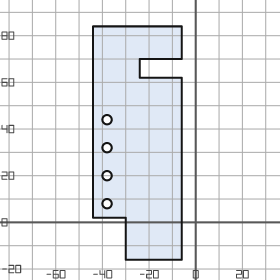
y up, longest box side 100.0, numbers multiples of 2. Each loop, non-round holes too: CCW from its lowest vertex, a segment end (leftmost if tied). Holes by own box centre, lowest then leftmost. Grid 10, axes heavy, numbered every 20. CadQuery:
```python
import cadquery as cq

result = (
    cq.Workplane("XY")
    .moveTo(-30.0, -16.0)
    .lineTo(-6.0, -16.0)
    .lineTo(-6.0, 62.0)
    .lineTo(-24.0, 62.0)
    .lineTo(-24.0, 70.0)
    .lineTo(-6.0, 70.0)
    .lineTo(-6.0, 84.0)
    .lineTo(-44.0, 84.0)
    .lineTo(-44.0, 2.0)
    .lineTo(-30.0, 2.0)
    .close()
    .moveTo(-38.0, 8.0)
    .circle(2.0)
    .moveTo(-38.0, 20.0)
    .circle(2.0)
    .moveTo(-38.0, 32.0)
    .circle(2.0)
    .moveTo(-38.0, 44.0)
    .circle(2.0)
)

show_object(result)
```